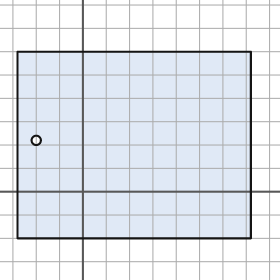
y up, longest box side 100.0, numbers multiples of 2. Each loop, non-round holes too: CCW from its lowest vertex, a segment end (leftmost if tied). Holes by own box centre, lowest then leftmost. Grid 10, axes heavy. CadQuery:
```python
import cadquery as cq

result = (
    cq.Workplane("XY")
    .moveTo(-28.0, -20.0)
    .lineTo(72.0, -20.0)
    .lineTo(72.0, 60.0)
    .lineTo(-28.0, 60.0)
    .close()
    .moveTo(-20.0, 22.0)
    .circle(2.0)
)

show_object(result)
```